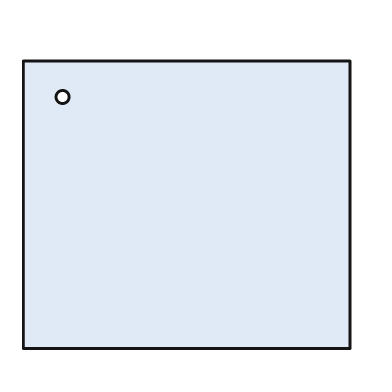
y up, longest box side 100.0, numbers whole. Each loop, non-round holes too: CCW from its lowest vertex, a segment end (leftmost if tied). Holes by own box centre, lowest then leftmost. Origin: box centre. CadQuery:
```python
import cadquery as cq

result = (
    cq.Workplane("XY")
    .moveTo(-50.0, -44.0)
    .lineTo(50.0, -44.0)
    .lineTo(50.0, 44.0)
    .lineTo(-50.0, 44.0)
    .close()
    .moveTo(-38.0, 33.0)
    .circle(2.0)
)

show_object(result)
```